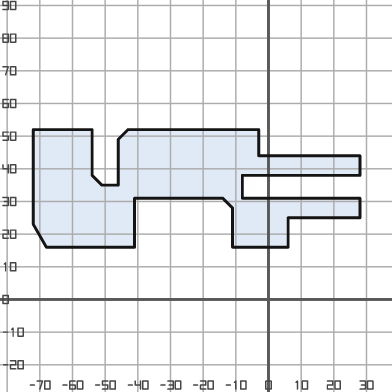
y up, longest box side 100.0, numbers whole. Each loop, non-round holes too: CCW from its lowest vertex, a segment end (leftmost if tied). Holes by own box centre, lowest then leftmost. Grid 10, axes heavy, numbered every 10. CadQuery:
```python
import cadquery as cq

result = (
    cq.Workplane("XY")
    .moveTo(-68.0, 16.0)
    .lineTo(-41.0, 16.0)
    .lineTo(-41.0, 31.0)
    .lineTo(-14.0, 31.0)
    .lineTo(-11.0, 28.0)
    .lineTo(-11.0, 16.0)
    .lineTo(6.0, 16.0)
    .lineTo(6.0, 25.0)
    .lineTo(28.0, 25.0)
    .lineTo(28.0, 31.0)
    .lineTo(-8.0, 31.0)
    .lineTo(-8.0, 38.0)
    .lineTo(28.0, 38.0)
    .lineTo(28.0, 44.0)
    .lineTo(-3.0, 44.0)
    .lineTo(-3.0, 52.0)
    .lineTo(-43.0, 52.0)
    .lineTo(-46.0, 49.0)
    .lineTo(-46.0, 35.0)
    .lineTo(-51.0, 35.0)
    .lineTo(-54.0, 38.0)
    .lineTo(-54.0, 52.0)
    .lineTo(-72.0, 52.0)
    .lineTo(-72.0, 23.0)
    .close()
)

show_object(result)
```